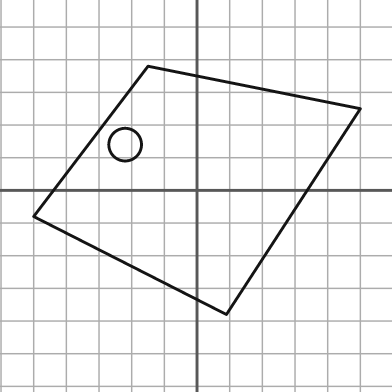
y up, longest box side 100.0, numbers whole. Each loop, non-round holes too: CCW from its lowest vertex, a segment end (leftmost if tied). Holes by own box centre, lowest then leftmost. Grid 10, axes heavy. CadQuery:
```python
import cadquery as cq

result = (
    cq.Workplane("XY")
    .moveTo(9.0, -38.0)
    .lineTo(50.0, 25.0)
    .lineTo(-15.0, 38.0)
    .lineTo(-50.0, -8.0)
    .close()
    .moveTo(-22.0, 14.0)
    .circle(5.0)
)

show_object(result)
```